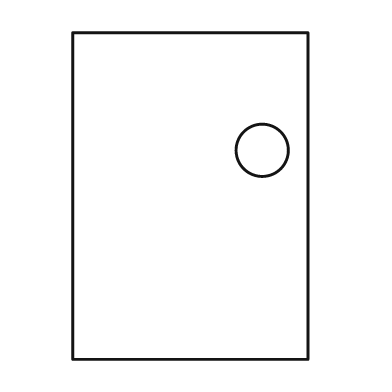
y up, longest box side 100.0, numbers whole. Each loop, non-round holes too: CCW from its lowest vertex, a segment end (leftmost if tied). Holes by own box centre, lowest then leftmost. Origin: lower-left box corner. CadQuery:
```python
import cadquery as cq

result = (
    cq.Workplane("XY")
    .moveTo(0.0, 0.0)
    .lineTo(72.0, 0.0)
    .lineTo(72.0, 100.0)
    .lineTo(0.0, 100.0)
    .close()
    .moveTo(58.0, 64.0)
    .circle(8.0)
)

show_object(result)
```